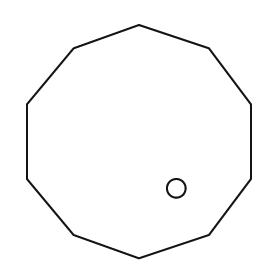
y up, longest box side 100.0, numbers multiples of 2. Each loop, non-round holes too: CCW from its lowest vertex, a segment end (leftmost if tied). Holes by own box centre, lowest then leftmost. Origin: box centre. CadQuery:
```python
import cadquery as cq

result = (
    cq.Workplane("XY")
    .moveTo(0.0, -50.0)
    .lineTo(30.0, -40.0)
    .lineTo(48.0, -16.0)
    .lineTo(48.0, 16.0)
    .lineTo(30.0, 40.0)
    .lineTo(0.0, 50.0)
    .lineTo(-28.0, 40.0)
    .lineTo(-48.0, 16.0)
    .lineTo(-48.0, -16.0)
    .lineTo(-28.0, -40.0)
    .close()
    .moveTo(16.0, -20.0)
    .circle(4.0)
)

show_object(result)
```